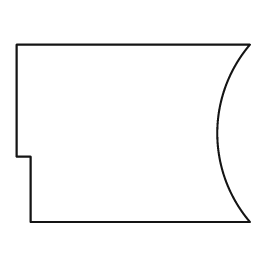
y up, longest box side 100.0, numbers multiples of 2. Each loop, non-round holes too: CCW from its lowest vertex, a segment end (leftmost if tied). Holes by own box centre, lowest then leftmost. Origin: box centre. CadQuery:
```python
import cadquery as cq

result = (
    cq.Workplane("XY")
    .moveTo(-44.0, -38.0)
    .lineTo(50.0, -38.0)
    .threePointArc((36.0, 0.0), (50.0, 38.0))
    .lineTo(-50.0, 38.0)
    .lineTo(-50.0, -10.0)
    .lineTo(-44.0, -10.0)
    .close()
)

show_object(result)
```